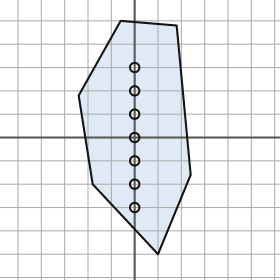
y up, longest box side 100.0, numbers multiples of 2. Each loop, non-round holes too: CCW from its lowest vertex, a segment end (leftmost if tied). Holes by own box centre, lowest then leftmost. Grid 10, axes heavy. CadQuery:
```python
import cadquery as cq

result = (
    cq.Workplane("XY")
    .moveTo(10.0, -50.0)
    .lineTo(24.0, -16.0)
    .lineTo(18.0, 48.0)
    .lineTo(-6.0, 50.0)
    .lineTo(-24.0, 18.0)
    .lineTo(-18.0, -20.0)
    .close()
    .moveTo(0.0, -30.0)
    .circle(2.0)
    .moveTo(0.0, -20.0)
    .circle(2.0)
    .moveTo(0.0, -10.0)
    .circle(2.0)
    .moveTo(0.0, 0.0)
    .circle(2.0)
    .moveTo(0.0, 10.0)
    .circle(2.0)
    .moveTo(0.0, 20.0)
    .circle(2.0)
    .moveTo(0.0, 30.0)
    .circle(2.0)
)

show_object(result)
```